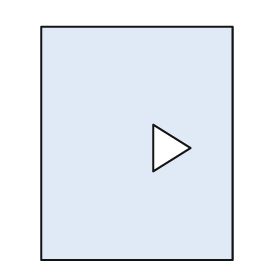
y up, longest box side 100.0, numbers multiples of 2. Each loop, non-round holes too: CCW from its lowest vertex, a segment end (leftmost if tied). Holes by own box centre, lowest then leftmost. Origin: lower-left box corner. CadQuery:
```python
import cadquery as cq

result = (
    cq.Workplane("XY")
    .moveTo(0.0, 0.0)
    .lineTo(82.0, 0.0)
    .lineTo(82.0, 100.0)
    .lineTo(0.0, 100.0)
    .close()
    .moveTo(48.0, 38.0)
    .lineTo(64.0, 48.0)
    .lineTo(48.0, 58.0)
    .close()
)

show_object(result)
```